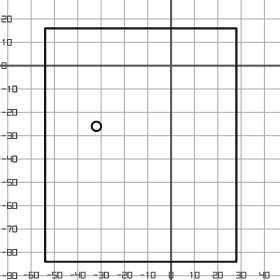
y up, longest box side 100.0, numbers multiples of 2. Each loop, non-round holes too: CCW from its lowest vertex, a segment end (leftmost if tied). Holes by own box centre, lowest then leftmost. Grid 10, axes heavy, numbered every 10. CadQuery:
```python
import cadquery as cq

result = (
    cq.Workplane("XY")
    .moveTo(-54.0, -84.0)
    .lineTo(28.0, -84.0)
    .lineTo(28.0, 16.0)
    .lineTo(-54.0, 16.0)
    .close()
    .moveTo(-32.0, -26.0)
    .circle(2.0)
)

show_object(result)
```